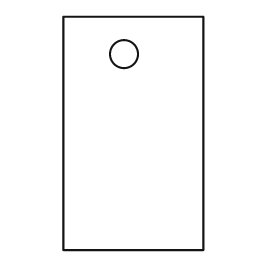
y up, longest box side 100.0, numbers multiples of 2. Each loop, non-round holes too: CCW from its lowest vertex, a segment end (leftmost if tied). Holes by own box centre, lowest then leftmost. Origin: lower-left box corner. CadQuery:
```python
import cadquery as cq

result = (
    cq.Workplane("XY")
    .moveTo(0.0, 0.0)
    .lineTo(60.0, 0.0)
    .lineTo(60.0, 100.0)
    .lineTo(0.0, 100.0)
    .close()
    .moveTo(26.0, 84.0)
    .circle(6.0)
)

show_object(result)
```